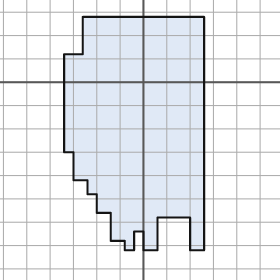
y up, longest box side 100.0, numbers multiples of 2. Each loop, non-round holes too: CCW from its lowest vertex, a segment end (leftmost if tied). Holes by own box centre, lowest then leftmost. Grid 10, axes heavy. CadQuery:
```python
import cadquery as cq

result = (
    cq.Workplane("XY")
    .moveTo(-8.0, -72.0)
    .lineTo(-4.0, -72.0)
    .lineTo(-4.0, -64.0)
    .lineTo(0.0, -64.0)
    .lineTo(0.0, -72.0)
    .lineTo(6.0, -72.0)
    .lineTo(6.0, -58.0)
    .lineTo(20.0, -58.0)
    .lineTo(20.0, -72.0)
    .lineTo(26.0, -72.0)
    .lineTo(26.0, 28.0)
    .lineTo(-26.0, 28.0)
    .lineTo(-26.0, 12.0)
    .lineTo(-34.0, 12.0)
    .lineTo(-34.0, -30.0)
    .lineTo(-30.0, -30.0)
    .lineTo(-30.0, -42.0)
    .lineTo(-24.0, -42.0)
    .lineTo(-24.0, -48.0)
    .lineTo(-20.0, -48.0)
    .lineTo(-20.0, -56.0)
    .lineTo(-14.0, -56.0)
    .lineTo(-14.0, -68.0)
    .lineTo(-8.0, -68.0)
    .close()
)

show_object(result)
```